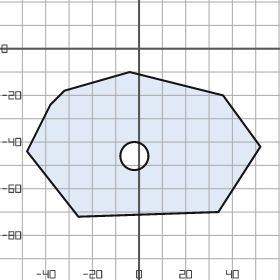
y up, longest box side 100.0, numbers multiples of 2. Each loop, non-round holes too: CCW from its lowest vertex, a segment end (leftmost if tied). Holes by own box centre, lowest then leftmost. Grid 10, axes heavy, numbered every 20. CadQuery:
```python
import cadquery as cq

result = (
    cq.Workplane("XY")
    .moveTo(-26.0, -72.0)
    .lineTo(34.0, -70.0)
    .lineTo(52.0, -42.0)
    .lineTo(36.0, -20.0)
    .lineTo(-4.0, -10.0)
    .lineTo(-32.0, -18.0)
    .lineTo(-38.0, -24.0)
    .lineTo(-48.0, -44.0)
    .close()
    .moveTo(-2.0, -46.0)
    .circle(6.0)
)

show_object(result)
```